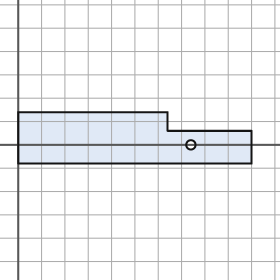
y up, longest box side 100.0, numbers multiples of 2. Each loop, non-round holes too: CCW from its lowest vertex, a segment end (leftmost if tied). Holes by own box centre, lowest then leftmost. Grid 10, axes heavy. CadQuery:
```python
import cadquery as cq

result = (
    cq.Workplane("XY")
    .moveTo(0.0, -8.0)
    .lineTo(100.0, -8.0)
    .lineTo(100.0, 6.0)
    .lineTo(64.0, 6.0)
    .lineTo(64.0, 14.0)
    .lineTo(0.0, 14.0)
    .close()
    .moveTo(74.0, 0.0)
    .circle(2.0)
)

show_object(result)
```